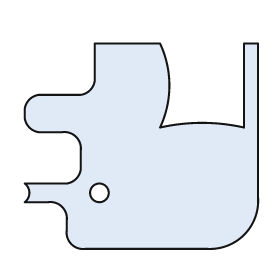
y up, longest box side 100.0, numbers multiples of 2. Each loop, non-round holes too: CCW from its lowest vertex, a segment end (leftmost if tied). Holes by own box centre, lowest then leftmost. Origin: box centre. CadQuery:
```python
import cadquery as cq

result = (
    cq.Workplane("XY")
    .moveTo(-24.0, -44.0)
    .lineTo(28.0, -44.0)
    .threePointArc((44.0, -38.0), (50.0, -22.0))
    .lineTo(50.0, 44.0)
    .lineTo(44.0, 44.0)
    .lineTo(44.0, 8.0)
    .threePointArc((26.0, 10.0), (8.0, 8.0))
    .threePointArc((12.0, 26.0), (8.0, 44.0))
    .lineTo(-20.0, 44.0)
    .lineTo(-20.0, 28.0)
    .threePointArc((-22.0, 24.0), (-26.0, 22.0))
    .lineTo(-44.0, 22.0)
    .threePointArc((-48.0, 20.0), (-50.0, 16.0))
    .lineTo(-50.0, 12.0)
    .threePointArc((-48.0, 8.0), (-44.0, 6.0))
    .lineTo(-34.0, 6.0)
    .threePointArc((-28.0, 4.0), (-26.0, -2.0))
    .lineTo(-26.0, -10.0)
    .threePointArc((-28.0, -14.0), (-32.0, -16.0))
    .lineTo(-50.0, -16.0)
    .threePointArc((-48.0, -20.0), (-50.0, -24.0))
    .lineTo(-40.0, -24.0)
    .threePointArc((-34.0, -26.0), (-32.0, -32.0))
    .lineTo(-32.0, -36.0)
    .threePointArc((-30.0, -42.0), (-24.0, -44.0))
    .close()
    .moveTo(-18.0, -20.0)
    .circle(4.0)
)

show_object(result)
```